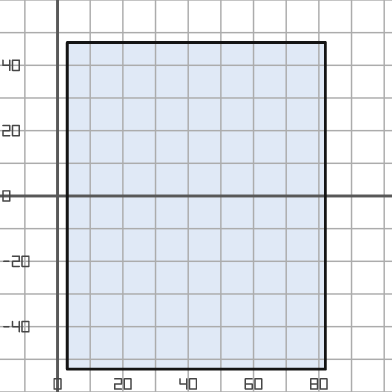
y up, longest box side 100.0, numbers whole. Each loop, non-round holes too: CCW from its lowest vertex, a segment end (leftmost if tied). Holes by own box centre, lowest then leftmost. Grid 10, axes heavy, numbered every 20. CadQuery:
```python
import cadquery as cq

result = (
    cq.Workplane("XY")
    .moveTo(3.0, -53.0)
    .lineTo(82.0, -53.0)
    .lineTo(82.0, 47.0)
    .lineTo(3.0, 47.0)
    .close()
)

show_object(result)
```